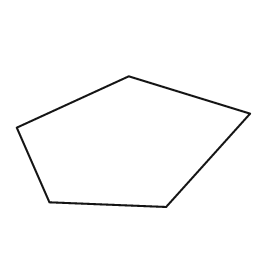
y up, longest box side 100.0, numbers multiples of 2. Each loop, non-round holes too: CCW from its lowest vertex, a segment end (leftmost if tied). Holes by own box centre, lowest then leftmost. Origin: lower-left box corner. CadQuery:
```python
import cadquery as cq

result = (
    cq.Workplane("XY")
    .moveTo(64.0, 0.0)
    .lineTo(100.0, 40.0)
    .lineTo(48.0, 56.0)
    .lineTo(0.0, 34.0)
    .lineTo(14.0, 2.0)
    .close()
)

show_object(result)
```